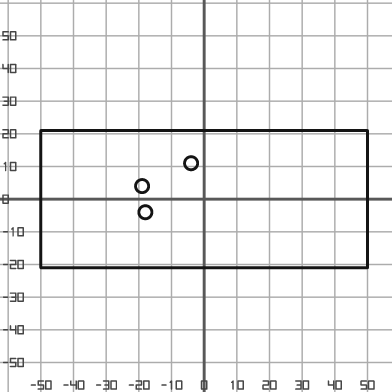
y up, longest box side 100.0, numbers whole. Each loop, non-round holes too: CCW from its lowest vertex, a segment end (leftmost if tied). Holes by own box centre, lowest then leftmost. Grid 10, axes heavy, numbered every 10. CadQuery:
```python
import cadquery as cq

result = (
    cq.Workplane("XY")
    .moveTo(-50.0, -21.0)
    .lineTo(50.0, -21.0)
    .lineTo(50.0, 21.0)
    .lineTo(-50.0, 21.0)
    .close()
    .moveTo(-18.0, -4.0)
    .circle(2.0)
    .moveTo(-19.0, 4.0)
    .circle(2.0)
    .moveTo(-4.0, 11.0)
    .circle(2.0)
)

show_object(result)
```